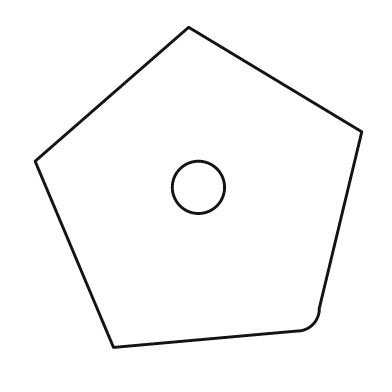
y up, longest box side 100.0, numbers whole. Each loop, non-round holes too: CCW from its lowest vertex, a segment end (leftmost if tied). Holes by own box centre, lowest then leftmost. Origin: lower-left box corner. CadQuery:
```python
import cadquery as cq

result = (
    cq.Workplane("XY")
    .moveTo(24.0, 0.0)
    .lineTo(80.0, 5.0)
    .threePointArc((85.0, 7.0), (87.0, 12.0))
    .lineTo(100.0, 66.0)
    .lineTo(47.0, 98.0)
    .lineTo(0.0, 57.0)
    .close()
    .moveTo(50.0, 49.0)
    .circle(8.0)
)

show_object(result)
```